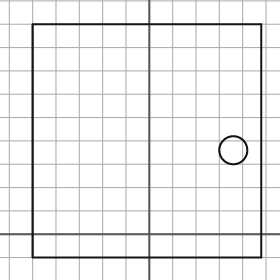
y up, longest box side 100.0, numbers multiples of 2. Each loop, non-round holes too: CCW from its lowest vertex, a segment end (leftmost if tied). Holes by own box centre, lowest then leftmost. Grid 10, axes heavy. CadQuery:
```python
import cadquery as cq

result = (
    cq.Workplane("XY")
    .moveTo(-50.0, -10.0)
    .lineTo(48.0, -10.0)
    .lineTo(48.0, 90.0)
    .lineTo(-50.0, 90.0)
    .close()
    .moveTo(36.0, 36.0)
    .circle(6.0)
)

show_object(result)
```